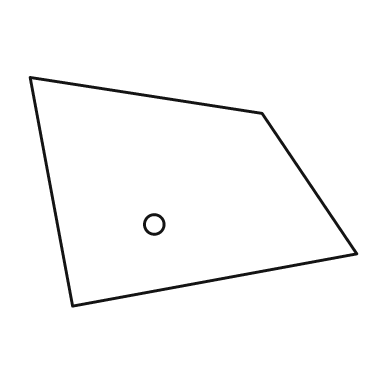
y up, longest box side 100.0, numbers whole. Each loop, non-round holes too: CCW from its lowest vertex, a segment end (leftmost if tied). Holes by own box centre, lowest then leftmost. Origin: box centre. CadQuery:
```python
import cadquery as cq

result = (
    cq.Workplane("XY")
    .moveTo(-37.0, -35.0)
    .lineTo(50.0, -19.0)
    .lineTo(21.0, 24.0)
    .lineTo(-50.0, 35.0)
    .close()
    .moveTo(-12.0, -10.0)
    .circle(3.0)
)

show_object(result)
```